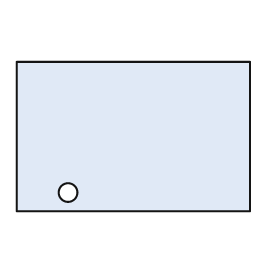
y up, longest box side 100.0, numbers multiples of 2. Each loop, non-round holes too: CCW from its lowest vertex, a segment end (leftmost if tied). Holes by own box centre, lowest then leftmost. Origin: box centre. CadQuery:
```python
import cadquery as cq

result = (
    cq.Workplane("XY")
    .moveTo(-50.0, -32.0)
    .lineTo(50.0, -32.0)
    .lineTo(50.0, 32.0)
    .lineTo(-50.0, 32.0)
    .close()
    .moveTo(-28.0, -24.0)
    .circle(4.0)
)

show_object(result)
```